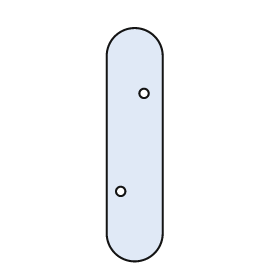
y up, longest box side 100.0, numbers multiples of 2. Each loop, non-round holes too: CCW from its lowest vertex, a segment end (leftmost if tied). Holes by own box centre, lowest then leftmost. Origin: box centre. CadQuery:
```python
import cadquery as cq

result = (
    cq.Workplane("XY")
    .moveTo(-12.0, -38.0)
    .threePointArc((0.0, -50.0), (12.0, -38.0))
    .lineTo(12.0, 38.0)
    .threePointArc((0.0, 50.0), (-12.0, 38.0))
    .close()
    .moveTo(-6.0, -20.0)
    .circle(2.0)
    .moveTo(4.0, 22.0)
    .circle(2.0)
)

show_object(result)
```